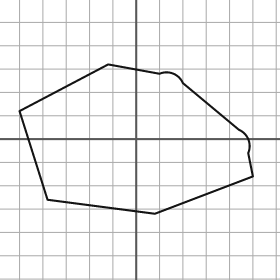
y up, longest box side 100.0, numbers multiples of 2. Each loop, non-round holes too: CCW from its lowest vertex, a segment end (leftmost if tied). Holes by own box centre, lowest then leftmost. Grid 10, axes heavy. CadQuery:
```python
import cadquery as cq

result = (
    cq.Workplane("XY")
    .moveTo(8.0, -32.0)
    .lineTo(50.0, -16.0)
    .lineTo(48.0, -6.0)
    .threePointArc((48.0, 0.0), (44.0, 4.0))
    .lineTo(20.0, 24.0)
    .threePointArc((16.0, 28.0), (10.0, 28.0))
    .lineTo(-12.0, 32.0)
    .lineTo(-50.0, 12.0)
    .lineTo(-38.0, -26.0)
    .close()
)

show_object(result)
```